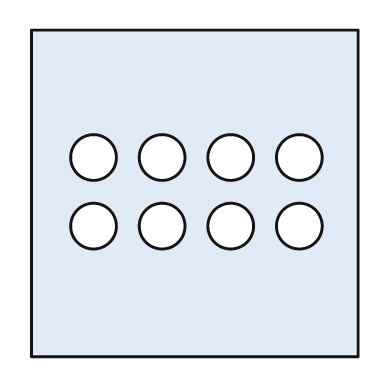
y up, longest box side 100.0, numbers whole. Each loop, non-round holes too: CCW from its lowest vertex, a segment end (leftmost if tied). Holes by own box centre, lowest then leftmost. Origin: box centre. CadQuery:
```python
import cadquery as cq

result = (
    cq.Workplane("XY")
    .moveTo(-50.0, -50.0)
    .lineTo(50.0, -50.0)
    .lineTo(50.0, 50.0)
    .lineTo(-50.0, 50.0)
    .close()
    .moveTo(-31.0, -10.0)
    .circle(7.0)
    .moveTo(-10.0, -10.0)
    .circle(7.0)
    .moveTo(11.0, -10.0)
    .circle(7.0)
    .moveTo(32.0, -10.0)
    .circle(7.0)
    .moveTo(-31.0, 11.0)
    .circle(7.0)
    .moveTo(-10.0, 11.0)
    .circle(7.0)
    .moveTo(11.0, 11.0)
    .circle(7.0)
    .moveTo(32.0, 11.0)
    .circle(7.0)
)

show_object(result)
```